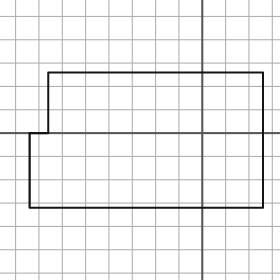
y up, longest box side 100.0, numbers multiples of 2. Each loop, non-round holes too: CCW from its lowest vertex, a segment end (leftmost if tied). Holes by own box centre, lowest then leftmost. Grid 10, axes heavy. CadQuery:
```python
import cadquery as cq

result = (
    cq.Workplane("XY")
    .moveTo(-74.0, -32.0)
    .lineTo(26.0, -32.0)
    .lineTo(26.0, 26.0)
    .lineTo(-66.0, 26.0)
    .lineTo(-66.0, 0.0)
    .lineTo(-74.0, 0.0)
    .close()
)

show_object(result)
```